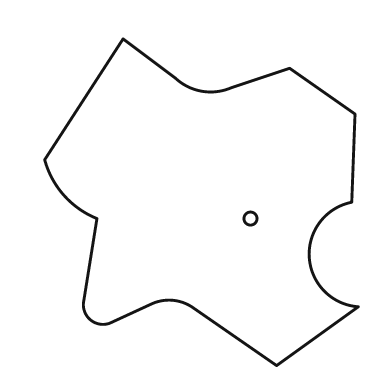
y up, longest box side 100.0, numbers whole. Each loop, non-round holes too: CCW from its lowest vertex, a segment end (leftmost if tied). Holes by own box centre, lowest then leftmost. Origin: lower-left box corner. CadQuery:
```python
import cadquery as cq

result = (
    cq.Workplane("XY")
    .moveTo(71.0, 0.0)
    .lineTo(96.0, 18.0)
    .threePointArc((81.0, 33.0), (94.0, 50.0))
    .lineTo(95.0, 77.0)
    .lineTo(75.0, 91.0)
    .lineTo(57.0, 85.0)
    .threePointArc((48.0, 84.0), (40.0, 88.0))
    .lineTo(24.0, 100.0)
    .lineTo(0.0, 63.0)
    .threePointArc((6.0, 52.0), (16.0, 45.0))
    .lineTo(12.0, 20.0)
    .threePointArc((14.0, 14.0), (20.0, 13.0))
    .lineTo(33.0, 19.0)
    .threePointArc((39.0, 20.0), (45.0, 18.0))
    .close()
    .moveTo(63.0, 45.0)
    .circle(2.0)
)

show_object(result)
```